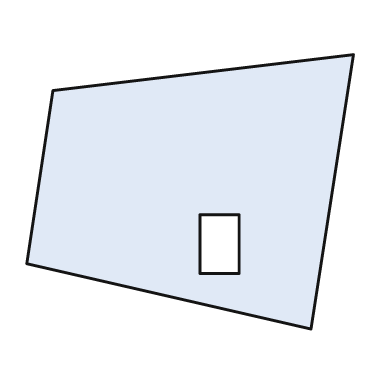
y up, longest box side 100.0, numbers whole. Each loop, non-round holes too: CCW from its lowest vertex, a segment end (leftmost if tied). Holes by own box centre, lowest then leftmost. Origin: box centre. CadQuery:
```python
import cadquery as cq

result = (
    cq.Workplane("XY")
    .moveTo(37.0, -42.0)
    .lineTo(50.0, 42.0)
    .lineTo(-42.0, 31.0)
    .lineTo(-50.0, -22.0)
    .close()
    .moveTo(3.0, -25.0)
    .lineTo(15.0, -25.0)
    .lineTo(15.0, -7.0)
    .lineTo(3.0, -7.0)
    .close()
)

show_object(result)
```